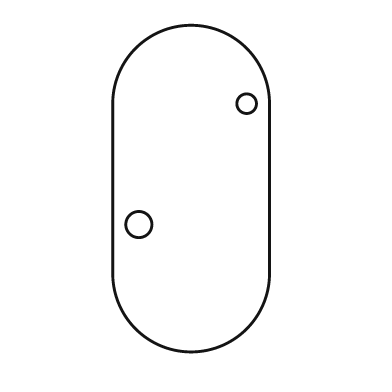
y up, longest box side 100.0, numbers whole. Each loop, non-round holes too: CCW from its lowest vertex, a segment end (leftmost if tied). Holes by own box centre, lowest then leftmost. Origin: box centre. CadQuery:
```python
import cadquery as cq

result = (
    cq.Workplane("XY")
    .moveTo(-24.0, -26.0)
    .threePointArc((0.0, -50.0), (24.0, -26.0))
    .lineTo(24.0, 26.0)
    .threePointArc((0.0, 50.0), (-24.0, 26.0))
    .close()
    .moveTo(-16.0, -11.0)
    .circle(4.0)
    .moveTo(17.0, 26.0)
    .circle(3.0)
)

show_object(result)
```